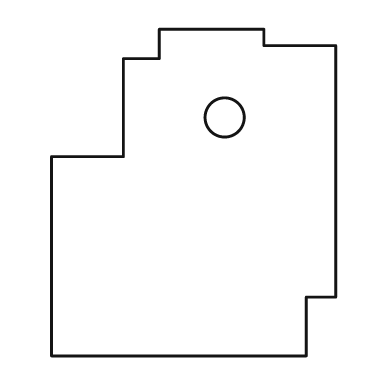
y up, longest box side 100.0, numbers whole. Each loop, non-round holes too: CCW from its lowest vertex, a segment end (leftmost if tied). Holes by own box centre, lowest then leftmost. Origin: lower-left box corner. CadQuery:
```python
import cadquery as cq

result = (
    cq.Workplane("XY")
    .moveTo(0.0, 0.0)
    .lineTo(78.0, 0.0)
    .lineTo(78.0, 18.0)
    .lineTo(87.0, 18.0)
    .lineTo(87.0, 95.0)
    .lineTo(65.0, 95.0)
    .lineTo(65.0, 100.0)
    .lineTo(33.0, 100.0)
    .lineTo(33.0, 91.0)
    .lineTo(22.0, 91.0)
    .lineTo(22.0, 61.0)
    .lineTo(0.0, 61.0)
    .close()
    .moveTo(53.0, 73.0)
    .circle(6.0)
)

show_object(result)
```